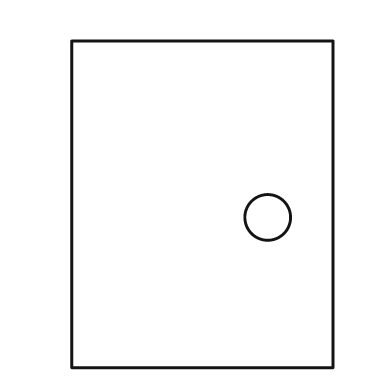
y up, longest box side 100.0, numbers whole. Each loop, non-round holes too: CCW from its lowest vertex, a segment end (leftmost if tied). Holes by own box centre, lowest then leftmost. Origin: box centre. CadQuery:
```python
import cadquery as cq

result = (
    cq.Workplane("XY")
    .moveTo(-40.0, -50.0)
    .lineTo(40.0, -50.0)
    .lineTo(40.0, 50.0)
    .lineTo(-40.0, 50.0)
    .close()
    .moveTo(20.0, -4.0)
    .circle(7.0)
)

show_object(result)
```